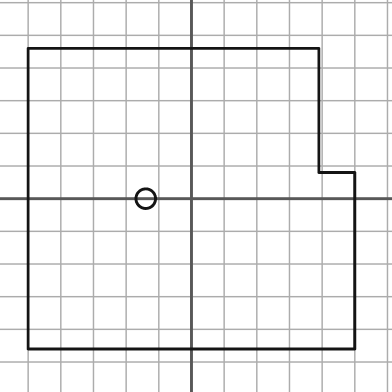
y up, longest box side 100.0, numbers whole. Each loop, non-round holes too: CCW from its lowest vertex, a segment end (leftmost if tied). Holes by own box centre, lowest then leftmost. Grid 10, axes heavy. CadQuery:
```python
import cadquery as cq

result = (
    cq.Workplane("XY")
    .moveTo(-50.0, -46.0)
    .lineTo(50.0, -46.0)
    .lineTo(50.0, 8.0)
    .lineTo(39.0, 8.0)
    .lineTo(39.0, 46.0)
    .lineTo(-50.0, 46.0)
    .close()
    .moveTo(-14.0, 0.0)
    .circle(3.0)
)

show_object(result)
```